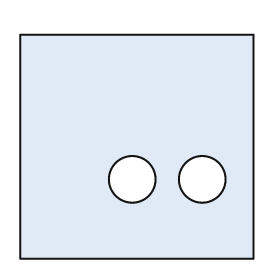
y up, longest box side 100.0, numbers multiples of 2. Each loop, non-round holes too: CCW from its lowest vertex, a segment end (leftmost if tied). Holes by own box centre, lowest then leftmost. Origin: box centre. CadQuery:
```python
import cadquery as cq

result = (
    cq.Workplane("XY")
    .moveTo(-50.0, -48.0)
    .lineTo(50.0, -48.0)
    .lineTo(50.0, 48.0)
    .lineTo(-50.0, 48.0)
    .close()
    .moveTo(-2.0, -14.0)
    .circle(10.0)
    .moveTo(28.0, -14.0)
    .circle(10.0)
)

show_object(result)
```